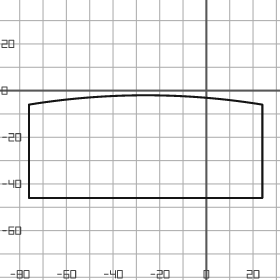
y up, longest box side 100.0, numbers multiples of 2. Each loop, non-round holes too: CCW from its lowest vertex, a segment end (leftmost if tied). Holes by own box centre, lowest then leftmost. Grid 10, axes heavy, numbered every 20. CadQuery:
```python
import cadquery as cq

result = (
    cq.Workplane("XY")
    .moveTo(-76.0, -46.0)
    .lineTo(24.0, -46.0)
    .lineTo(24.0, -6.0)
    .threePointArc((-26.0, -2.0), (-76.0, -6.0))
    .close()
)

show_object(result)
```